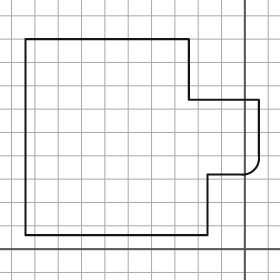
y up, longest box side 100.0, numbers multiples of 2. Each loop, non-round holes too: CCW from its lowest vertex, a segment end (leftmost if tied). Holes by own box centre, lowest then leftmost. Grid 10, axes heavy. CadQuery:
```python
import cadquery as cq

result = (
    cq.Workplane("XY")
    .moveTo(-94.0, 6.0)
    .lineTo(-16.0, 6.0)
    .lineTo(-16.0, 32.0)
    .lineTo(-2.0, 32.0)
    .threePointArc((4.0, 34.0), (6.0, 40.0))
    .lineTo(6.0, 64.0)
    .lineTo(-24.0, 64.0)
    .lineTo(-24.0, 90.0)
    .lineTo(-94.0, 90.0)
    .close()
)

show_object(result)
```